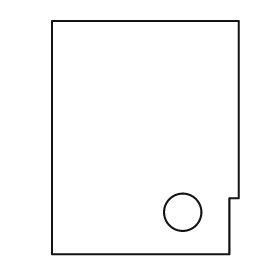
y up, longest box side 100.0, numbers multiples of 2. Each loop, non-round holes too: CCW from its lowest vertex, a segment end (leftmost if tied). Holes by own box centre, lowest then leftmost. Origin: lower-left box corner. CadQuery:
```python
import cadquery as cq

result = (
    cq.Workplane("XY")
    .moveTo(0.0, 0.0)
    .lineTo(76.0, 0.0)
    .lineTo(76.0, 24.0)
    .lineTo(80.0, 24.0)
    .lineTo(80.0, 100.0)
    .lineTo(0.0, 100.0)
    .close()
    .moveTo(56.0, 18.0)
    .circle(8.0)
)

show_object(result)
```